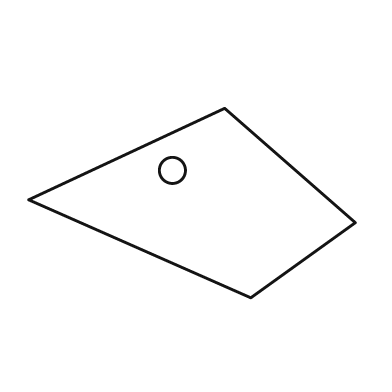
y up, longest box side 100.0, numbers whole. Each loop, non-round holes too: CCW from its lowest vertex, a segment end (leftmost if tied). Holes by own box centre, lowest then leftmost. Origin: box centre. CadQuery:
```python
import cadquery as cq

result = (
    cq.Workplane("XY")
    .moveTo(18.0, -29.0)
    .lineTo(50.0, -6.0)
    .lineTo(10.0, 29.0)
    .lineTo(-50.0, 1.0)
    .close()
    .moveTo(-6.0, 10.0)
    .circle(4.0)
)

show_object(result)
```